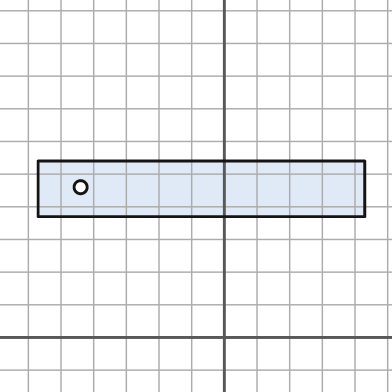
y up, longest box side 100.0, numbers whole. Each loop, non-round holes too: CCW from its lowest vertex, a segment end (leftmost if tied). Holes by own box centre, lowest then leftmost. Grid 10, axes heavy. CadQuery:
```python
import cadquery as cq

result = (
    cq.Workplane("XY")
    .moveTo(-57.0, 37.0)
    .lineTo(43.0, 37.0)
    .lineTo(43.0, 54.0)
    .lineTo(-57.0, 54.0)
    .close()
    .moveTo(-44.0, 46.0)
    .circle(2.0)
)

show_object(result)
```